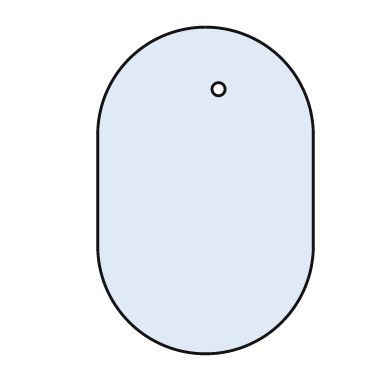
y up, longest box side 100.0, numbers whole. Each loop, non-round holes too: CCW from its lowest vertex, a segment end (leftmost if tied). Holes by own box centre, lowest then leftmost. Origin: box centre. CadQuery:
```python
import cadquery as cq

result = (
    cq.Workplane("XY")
    .moveTo(-33.0, -17.0)
    .threePointArc((0.0, -50.0), (33.0, -17.0))
    .lineTo(33.0, 17.0)
    .threePointArc((0.0, 50.0), (-33.0, 17.0))
    .close()
    .moveTo(4.0, 31.0)
    .circle(2.0)
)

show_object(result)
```